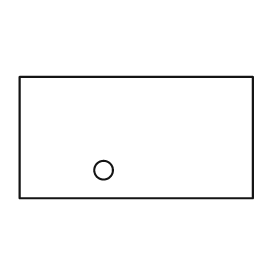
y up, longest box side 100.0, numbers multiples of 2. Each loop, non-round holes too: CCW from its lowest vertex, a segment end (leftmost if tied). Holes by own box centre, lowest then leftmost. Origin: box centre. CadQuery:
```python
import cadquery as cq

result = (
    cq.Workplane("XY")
    .moveTo(-50.0, -26.0)
    .lineTo(50.0, -26.0)
    .lineTo(50.0, 26.0)
    .lineTo(-50.0, 26.0)
    .close()
    .moveTo(-14.0, -14.0)
    .circle(4.0)
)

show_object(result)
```